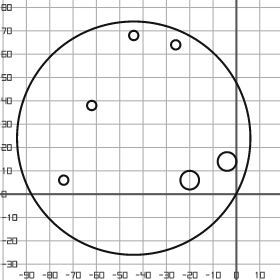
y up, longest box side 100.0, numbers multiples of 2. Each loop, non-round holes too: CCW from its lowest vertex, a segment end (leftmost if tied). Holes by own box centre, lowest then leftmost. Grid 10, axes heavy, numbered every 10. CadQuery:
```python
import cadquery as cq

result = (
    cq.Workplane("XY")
    .moveTo(-44.0, 24.0)
    .circle(50.0)
    .moveTo(-74.0, 6.0)
    .circle(2.0)
    .moveTo(-20.0, 6.0)
    .circle(4.0)
    .moveTo(-4.0, 14.0)
    .circle(4.0)
    .moveTo(-62.0, 38.0)
    .circle(2.0)
    .moveTo(-26.0, 64.0)
    .circle(2.0)
    .moveTo(-44.0, 68.0)
    .circle(2.0)
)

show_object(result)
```